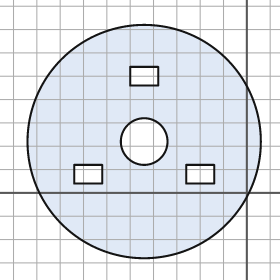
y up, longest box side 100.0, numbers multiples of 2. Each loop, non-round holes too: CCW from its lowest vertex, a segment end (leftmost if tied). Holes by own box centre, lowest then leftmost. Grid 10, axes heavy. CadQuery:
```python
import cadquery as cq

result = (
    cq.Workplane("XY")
    .moveTo(-44.0, 22.0)
    .circle(50.0)
    .moveTo(-74.0, 4.0)
    .lineTo(-62.0, 4.0)
    .lineTo(-62.0, 12.0)
    .lineTo(-74.0, 12.0)
    .close()
    .moveTo(-26.0, 4.0)
    .lineTo(-14.0, 4.0)
    .lineTo(-14.0, 12.0)
    .lineTo(-26.0, 12.0)
    .close()
    .moveTo(-44.0, 22.0)
    .circle(10.0)
    .moveTo(-50.0, 46.0)
    .lineTo(-38.0, 46.0)
    .lineTo(-38.0, 54.0)
    .lineTo(-50.0, 54.0)
    .close()
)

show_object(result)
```